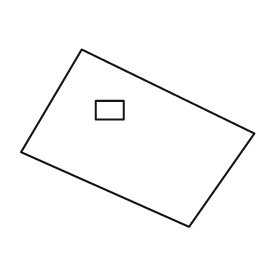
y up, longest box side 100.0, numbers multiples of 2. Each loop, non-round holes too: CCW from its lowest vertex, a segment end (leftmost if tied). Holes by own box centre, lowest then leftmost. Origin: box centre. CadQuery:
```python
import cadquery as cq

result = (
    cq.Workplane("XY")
    .moveTo(22.0, -38.0)
    .lineTo(50.0, 2.0)
    .lineTo(-24.0, 38.0)
    .lineTo(-50.0, -6.0)
    .close()
    .moveTo(-18.0, 8.0)
    .lineTo(-6.0, 8.0)
    .lineTo(-6.0, 16.0)
    .lineTo(-18.0, 16.0)
    .close()
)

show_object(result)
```